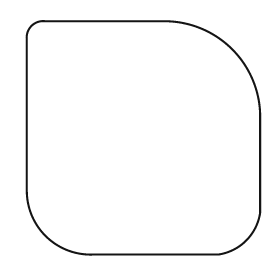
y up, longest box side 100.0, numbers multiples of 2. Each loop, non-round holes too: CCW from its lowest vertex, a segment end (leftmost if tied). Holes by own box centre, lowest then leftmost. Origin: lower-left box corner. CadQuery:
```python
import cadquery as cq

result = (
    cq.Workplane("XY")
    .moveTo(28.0, 0.0)
    .lineTo(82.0, 0.0)
    .threePointArc((94.0, 6.0), (100.0, 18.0))
    .lineTo(100.0, 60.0)
    .threePointArc((88.0, 88.0), (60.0, 100.0))
    .lineTo(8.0, 100.0)
    .threePointArc((2.0, 98.0), (0.0, 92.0))
    .lineTo(0.0, 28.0)
    .threePointArc((8.0, 8.0), (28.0, 0.0))
    .close()
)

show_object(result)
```